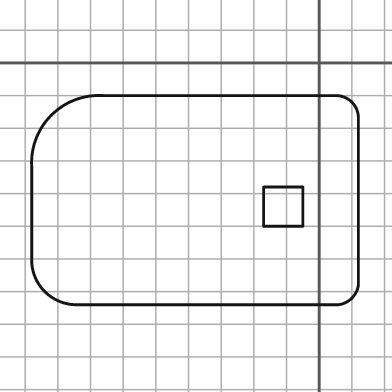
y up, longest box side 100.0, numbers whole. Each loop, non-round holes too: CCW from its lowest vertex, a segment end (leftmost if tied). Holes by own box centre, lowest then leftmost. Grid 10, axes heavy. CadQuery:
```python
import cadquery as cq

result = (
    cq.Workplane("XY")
    .moveTo(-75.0, -74.0)
    .lineTo(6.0, -74.0)
    .threePointArc((10.0, -72.0), (12.0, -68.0))
    .lineTo(12.0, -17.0)
    .threePointArc((10.0, -12.0), (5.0, -10.0))
    .lineTo(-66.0, -10.0)
    .threePointArc((-82.0, -16.0), (-88.0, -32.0))
    .lineTo(-88.0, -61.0)
    .threePointArc((-84.0, -70.0), (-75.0, -74.0))
    .close()
    .moveTo(-17.0, -50.0)
    .lineTo(-5.0, -50.0)
    .lineTo(-5.0, -38.0)
    .lineTo(-17.0, -38.0)
    .close()
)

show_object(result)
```